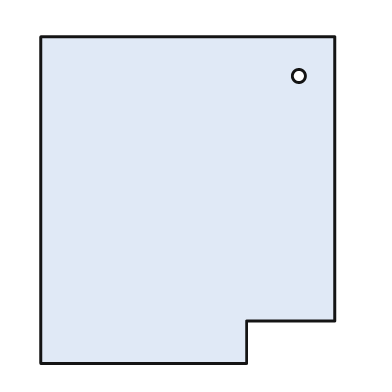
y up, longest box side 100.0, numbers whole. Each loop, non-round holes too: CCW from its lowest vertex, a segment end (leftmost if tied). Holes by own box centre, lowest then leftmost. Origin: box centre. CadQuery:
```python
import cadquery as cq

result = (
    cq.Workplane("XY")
    .moveTo(-45.0, -50.0)
    .lineTo(18.0, -50.0)
    .lineTo(18.0, -37.0)
    .lineTo(45.0, -37.0)
    .lineTo(45.0, 50.0)
    .lineTo(-45.0, 50.0)
    .close()
    .moveTo(34.0, 38.0)
    .circle(2.0)
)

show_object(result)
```